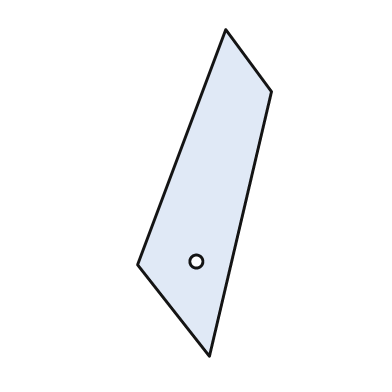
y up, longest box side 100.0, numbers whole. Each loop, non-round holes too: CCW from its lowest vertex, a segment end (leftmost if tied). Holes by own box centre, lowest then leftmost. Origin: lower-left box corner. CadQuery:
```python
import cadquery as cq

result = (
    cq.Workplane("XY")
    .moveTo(22.0, 0.0)
    .lineTo(41.0, 81.0)
    .lineTo(27.0, 100.0)
    .lineTo(0.0, 28.0)
    .close()
    .moveTo(18.0, 29.0)
    .circle(2.0)
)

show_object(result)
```